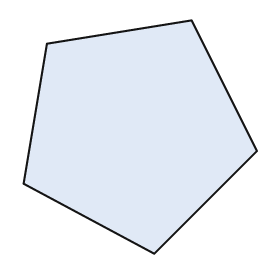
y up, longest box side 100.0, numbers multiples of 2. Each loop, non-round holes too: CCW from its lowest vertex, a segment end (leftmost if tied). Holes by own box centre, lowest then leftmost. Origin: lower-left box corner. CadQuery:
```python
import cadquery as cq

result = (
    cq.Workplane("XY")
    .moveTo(56.0, 0.0)
    .lineTo(100.0, 44.0)
    .lineTo(72.0, 100.0)
    .lineTo(10.0, 90.0)
    .lineTo(0.0, 30.0)
    .close()
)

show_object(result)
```